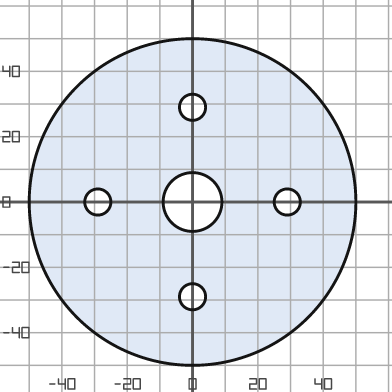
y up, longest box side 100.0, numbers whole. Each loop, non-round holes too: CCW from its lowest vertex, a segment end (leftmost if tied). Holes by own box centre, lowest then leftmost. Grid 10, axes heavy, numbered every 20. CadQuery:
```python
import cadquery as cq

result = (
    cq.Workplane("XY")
    .moveTo(0.0, 0.0)
    .circle(50.0)
    .moveTo(0.0, -29.0)
    .circle(4.0)
    .moveTo(-29.0, 0.0)
    .circle(4.0)
    .moveTo(0.0, 0.0)
    .circle(9.0)
    .moveTo(29.0, 0.0)
    .circle(4.0)
    .moveTo(0.0, 29.0)
    .circle(4.0)
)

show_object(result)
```